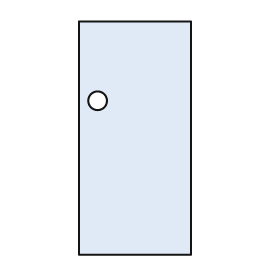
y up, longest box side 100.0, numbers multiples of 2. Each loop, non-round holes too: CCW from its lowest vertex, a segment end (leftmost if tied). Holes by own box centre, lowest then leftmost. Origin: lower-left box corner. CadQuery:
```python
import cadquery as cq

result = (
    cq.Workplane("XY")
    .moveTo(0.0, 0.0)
    .lineTo(48.0, 0.0)
    .lineTo(48.0, 100.0)
    .lineTo(0.0, 100.0)
    .close()
    .moveTo(8.0, 66.0)
    .circle(4.0)
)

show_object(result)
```